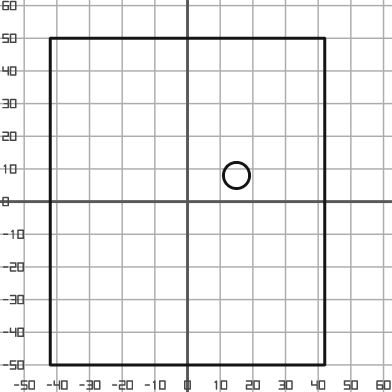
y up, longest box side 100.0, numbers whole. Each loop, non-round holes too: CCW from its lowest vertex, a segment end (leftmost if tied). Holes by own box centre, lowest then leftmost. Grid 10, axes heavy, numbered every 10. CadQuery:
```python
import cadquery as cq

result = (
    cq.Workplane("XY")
    .moveTo(-42.0, -50.0)
    .lineTo(42.0, -50.0)
    .lineTo(42.0, 50.0)
    .lineTo(-42.0, 50.0)
    .close()
    .moveTo(15.0, 8.0)
    .circle(4.0)
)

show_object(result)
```